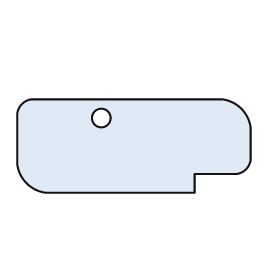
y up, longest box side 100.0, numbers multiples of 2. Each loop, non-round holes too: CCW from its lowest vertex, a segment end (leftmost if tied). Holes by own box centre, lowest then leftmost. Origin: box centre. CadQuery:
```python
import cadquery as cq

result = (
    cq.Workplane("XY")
    .moveTo(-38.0, -20.0)
    .lineTo(26.0, -20.0)
    .lineTo(26.0, -12.0)
    .lineTo(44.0, -12.0)
    .threePointArc((48.0, -10.0), (50.0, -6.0))
    .lineTo(50.0, 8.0)
    .threePointArc((46.0, 16.0), (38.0, 20.0))
    .lineTo(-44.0, 20.0)
    .threePointArc((-48.0, 18.0), (-50.0, 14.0))
    .lineTo(-50.0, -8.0)
    .threePointArc((-46.0, -16.0), (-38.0, -20.0))
    .close()
    .moveTo(-14.0, 12.0)
    .circle(4.0)
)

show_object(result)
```